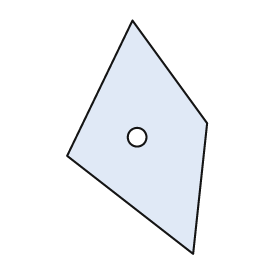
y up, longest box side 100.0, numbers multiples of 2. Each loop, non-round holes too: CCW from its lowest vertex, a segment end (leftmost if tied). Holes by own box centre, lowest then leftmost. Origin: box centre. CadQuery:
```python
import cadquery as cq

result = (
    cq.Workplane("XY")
    .moveTo(24.0, -50.0)
    .lineTo(30.0, 6.0)
    .lineTo(-2.0, 50.0)
    .lineTo(-30.0, -8.0)
    .close()
    .moveTo(0.0, 0.0)
    .circle(4.0)
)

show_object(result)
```